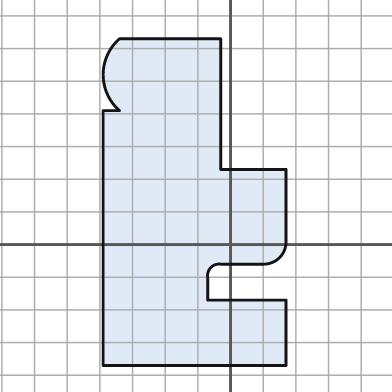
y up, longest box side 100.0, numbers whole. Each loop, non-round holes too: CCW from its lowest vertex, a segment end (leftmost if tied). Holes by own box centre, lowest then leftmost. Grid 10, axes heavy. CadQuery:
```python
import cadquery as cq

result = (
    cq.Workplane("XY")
    .moveTo(-39.0, -37.0)
    .lineTo(17.0, -37.0)
    .lineTo(17.0, -17.0)
    .lineTo(-7.0, -17.0)
    .lineTo(-7.0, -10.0)
    .threePointArc((-6.0, -7.0), (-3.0, -6.0))
    .lineTo(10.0, -6.0)
    .threePointArc((15.0, -4.0), (17.0, 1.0))
    .lineTo(17.0, 23.0)
    .lineTo(-3.0, 23.0)
    .lineTo(-3.0, 63.0)
    .lineTo(-34.0, 63.0)
    .threePointArc((-39.0, 52.0), (-34.0, 41.0))
    .lineTo(-39.0, 41.0)
    .close()
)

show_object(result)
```